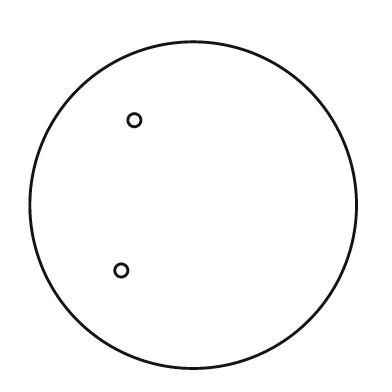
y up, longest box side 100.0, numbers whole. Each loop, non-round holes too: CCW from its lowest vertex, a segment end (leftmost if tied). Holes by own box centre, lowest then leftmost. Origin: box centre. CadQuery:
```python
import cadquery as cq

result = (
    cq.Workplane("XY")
    .moveTo(0.0, 0.0)
    .circle(50.0)
    .moveTo(-22.0, -20.0)
    .circle(2.0)
    .moveTo(-18.0, 26.0)
    .circle(2.0)
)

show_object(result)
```